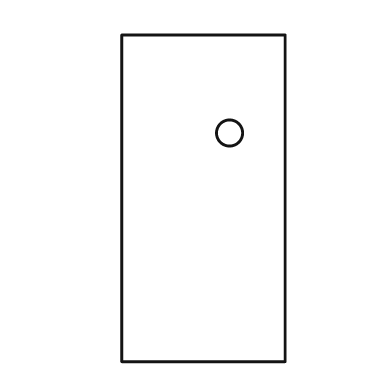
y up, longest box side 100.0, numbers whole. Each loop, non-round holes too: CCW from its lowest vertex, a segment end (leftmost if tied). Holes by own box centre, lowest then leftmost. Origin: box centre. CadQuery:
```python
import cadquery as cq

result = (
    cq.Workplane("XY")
    .moveTo(-25.0, -50.0)
    .lineTo(25.0, -50.0)
    .lineTo(25.0, 50.0)
    .lineTo(-25.0, 50.0)
    .close()
    .moveTo(8.0, 20.0)
    .circle(4.0)
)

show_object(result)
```